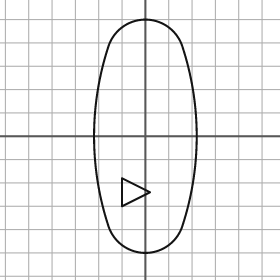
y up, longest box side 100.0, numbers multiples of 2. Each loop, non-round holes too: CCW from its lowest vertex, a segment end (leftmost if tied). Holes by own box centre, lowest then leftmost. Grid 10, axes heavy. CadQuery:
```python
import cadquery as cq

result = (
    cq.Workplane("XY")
    .moveTo(-16.0, -38.0)
    .threePointArc((0.0, -50.0), (16.0, -38.0))
    .threePointArc((22.0, 0.0), (16.0, 38.0))
    .threePointArc((0.0, 50.0), (-16.0, 38.0))
    .threePointArc((-22.0, 0.0), (-16.0, -38.0))
    .close()
    .moveTo(-10.0, -30.0)
    .lineTo(2.0, -24.0)
    .lineTo(-10.0, -18.0)
    .close()
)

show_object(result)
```